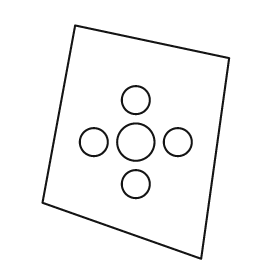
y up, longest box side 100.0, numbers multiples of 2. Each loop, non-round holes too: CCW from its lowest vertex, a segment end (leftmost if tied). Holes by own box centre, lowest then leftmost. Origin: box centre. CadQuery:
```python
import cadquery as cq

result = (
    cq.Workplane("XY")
    .moveTo(28.0, -50.0)
    .lineTo(40.0, 36.0)
    .lineTo(-26.0, 50.0)
    .lineTo(-40.0, -26.0)
    .close()
    .moveTo(0.0, -18.0)
    .circle(6.0)
    .moveTo(-18.0, 0.0)
    .circle(6.0)
    .moveTo(0.0, 0.0)
    .circle(8.0)
    .moveTo(18.0, 0.0)
    .circle(6.0)
    .moveTo(0.0, 18.0)
    .circle(6.0)
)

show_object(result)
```